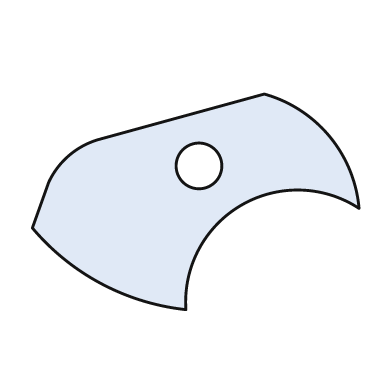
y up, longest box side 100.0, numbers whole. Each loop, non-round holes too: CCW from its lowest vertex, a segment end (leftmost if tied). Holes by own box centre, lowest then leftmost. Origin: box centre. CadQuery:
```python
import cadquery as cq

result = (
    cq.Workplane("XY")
    .moveTo(-3.0, -33.0)
    .threePointArc((14.0, -1.0), (50.0, -2.0))
    .threePointArc((41.0, 20.0), (21.0, 33.0))
    .lineTo(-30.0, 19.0)
    .threePointArc((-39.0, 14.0), (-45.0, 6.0))
    .lineTo(-50.0, -8.0)
    .threePointArc((-29.0, -25.0), (-3.0, -33.0))
    .close()
    .moveTo(1.0, 11.0)
    .circle(7.0)
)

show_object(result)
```